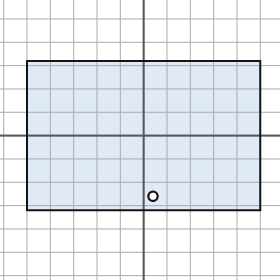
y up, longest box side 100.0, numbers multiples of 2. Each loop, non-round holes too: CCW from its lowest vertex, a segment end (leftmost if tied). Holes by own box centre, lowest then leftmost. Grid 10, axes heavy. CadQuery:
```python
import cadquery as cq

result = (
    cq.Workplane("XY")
    .moveTo(-50.0, -32.0)
    .lineTo(50.0, -32.0)
    .lineTo(50.0, 32.0)
    .lineTo(-50.0, 32.0)
    .close()
    .moveTo(4.0, -26.0)
    .circle(2.0)
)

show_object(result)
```